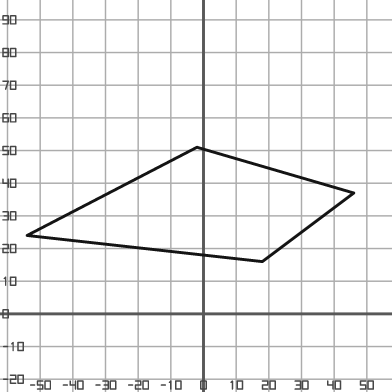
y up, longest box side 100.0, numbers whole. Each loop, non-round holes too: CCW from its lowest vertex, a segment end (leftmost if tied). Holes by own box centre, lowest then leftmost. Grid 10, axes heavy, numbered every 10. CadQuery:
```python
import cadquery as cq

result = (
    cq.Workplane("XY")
    .moveTo(18.0, 16.0)
    .lineTo(46.0, 37.0)
    .lineTo(-2.0, 51.0)
    .lineTo(-54.0, 24.0)
    .close()
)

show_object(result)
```